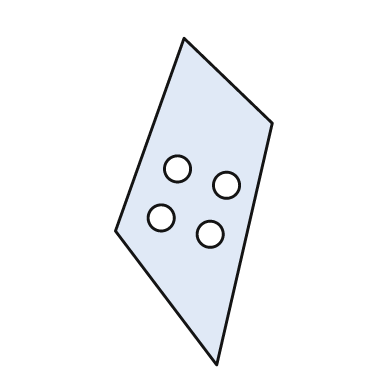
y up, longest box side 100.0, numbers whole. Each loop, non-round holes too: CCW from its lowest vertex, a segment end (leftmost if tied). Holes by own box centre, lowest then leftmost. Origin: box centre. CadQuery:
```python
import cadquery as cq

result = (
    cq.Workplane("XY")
    .moveTo(7.0, -50.0)
    .lineTo(24.0, 24.0)
    .lineTo(-3.0, 50.0)
    .lineTo(-24.0, -9.0)
    .close()
    .moveTo(5.0, -10.0)
    .circle(4.0)
    .moveTo(-10.0, -5.0)
    .circle(4.0)
    .moveTo(10.0, 5.0)
    .circle(4.0)
    .moveTo(-5.0, 10.0)
    .circle(4.0)
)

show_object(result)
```